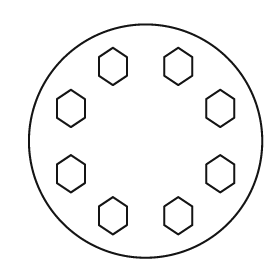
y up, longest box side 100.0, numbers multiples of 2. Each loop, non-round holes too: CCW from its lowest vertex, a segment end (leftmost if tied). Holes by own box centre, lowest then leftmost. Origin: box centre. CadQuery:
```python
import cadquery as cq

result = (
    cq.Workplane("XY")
    .moveTo(0.0, 0.0)
    .circle(50.0)
    .moveTo(-14.0, -40.0)
    .lineTo(-8.0, -36.0)
    .lineTo(-8.0, -28.0)
    .lineTo(-14.0, -24.0)
    .lineTo(-20.0, -28.0)
    .lineTo(-20.0, -36.0)
    .close()
    .moveTo(14.0, -40.0)
    .lineTo(20.0, -36.0)
    .lineTo(20.0, -28.0)
    .lineTo(14.0, -24.0)
    .lineTo(8.0, -28.0)
    .lineTo(8.0, -36.0)
    .close()
    .moveTo(-32.0, -22.0)
    .lineTo(-26.0, -18.0)
    .lineTo(-26.0, -10.0)
    .lineTo(-32.0, -6.0)
    .lineTo(-38.0, -10.0)
    .lineTo(-38.0, -18.0)
    .close()
    .moveTo(32.0, -22.0)
    .lineTo(38.0, -18.0)
    .lineTo(38.0, -10.0)
    .lineTo(32.0, -6.0)
    .lineTo(26.0, -10.0)
    .lineTo(26.0, -18.0)
    .close()
    .moveTo(-32.0, 6.0)
    .lineTo(-26.0, 10.0)
    .lineTo(-26.0, 18.0)
    .lineTo(-32.0, 22.0)
    .lineTo(-38.0, 18.0)
    .lineTo(-38.0, 10.0)
    .close()
    .moveTo(32.0, 6.0)
    .lineTo(38.0, 10.0)
    .lineTo(38.0, 18.0)
    .lineTo(32.0, 22.0)
    .lineTo(26.0, 18.0)
    .lineTo(26.0, 10.0)
    .close()
    .moveTo(-14.0, 24.0)
    .lineTo(-8.0, 28.0)
    .lineTo(-8.0, 36.0)
    .lineTo(-14.0, 40.0)
    .lineTo(-20.0, 36.0)
    .lineTo(-20.0, 28.0)
    .close()
    .moveTo(14.0, 24.0)
    .lineTo(20.0, 28.0)
    .lineTo(20.0, 36.0)
    .lineTo(14.0, 40.0)
    .lineTo(8.0, 36.0)
    .lineTo(8.0, 28.0)
    .close()
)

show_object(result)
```